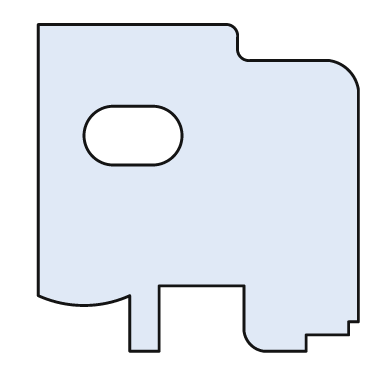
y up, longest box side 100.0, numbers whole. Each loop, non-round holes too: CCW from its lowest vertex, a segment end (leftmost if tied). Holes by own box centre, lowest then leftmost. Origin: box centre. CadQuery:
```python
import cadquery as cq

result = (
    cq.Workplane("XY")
    .moveTo(-21.0, -50.0)
    .lineTo(-12.0, -50.0)
    .lineTo(-12.0, -30.0)
    .lineTo(14.0, -30.0)
    .lineTo(14.0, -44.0)
    .threePointArc((16.0, -48.0), (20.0, -50.0))
    .lineTo(33.0, -50.0)
    .lineTo(33.0, -45.0)
    .lineTo(46.0, -45.0)
    .lineTo(46.0, -41.0)
    .lineTo(49.0, -41.0)
    .lineTo(49.0, 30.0)
    .threePointArc((46.0, 36.0), (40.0, 39.0))
    .lineTo(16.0, 39.0)
    .threePointArc((13.0, 40.0), (12.0, 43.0))
    .lineTo(12.0, 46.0)
    .threePointArc((11.0, 49.0), (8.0, 50.0))
    .lineTo(-49.0, 50.0)
    .lineTo(-49.0, -33.0)
    .threePointArc((-35.0, -36.0), (-21.0, -33.0))
    .close()
    .moveTo(-26.0, 7.0)
    .lineTo(-14.0, 7.0)
    .threePointArc((-5.0, 16.0), (-14.0, 25.0))
    .lineTo(-26.0, 25.0)
    .threePointArc((-35.0, 16.0), (-26.0, 7.0))
    .close()
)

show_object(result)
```